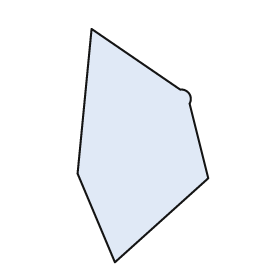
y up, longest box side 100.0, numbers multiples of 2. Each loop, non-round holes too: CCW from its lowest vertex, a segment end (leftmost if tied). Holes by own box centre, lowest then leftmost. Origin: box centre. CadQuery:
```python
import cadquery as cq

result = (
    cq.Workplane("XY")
    .moveTo(-12.0, -50.0)
    .lineTo(28.0, -14.0)
    .lineTo(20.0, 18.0)
    .threePointArc((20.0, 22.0), (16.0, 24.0))
    .lineTo(-22.0, 50.0)
    .lineTo(-28.0, -12.0)
    .close()
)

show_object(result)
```